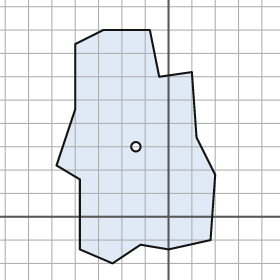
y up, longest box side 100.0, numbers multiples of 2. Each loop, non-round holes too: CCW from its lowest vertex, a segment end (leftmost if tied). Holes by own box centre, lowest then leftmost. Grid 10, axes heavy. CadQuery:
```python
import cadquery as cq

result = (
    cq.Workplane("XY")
    .moveTo(-24.0, -20.0)
    .lineTo(-12.0, -12.0)
    .lineTo(0.0, -14.0)
    .lineTo(18.0, -10.0)
    .lineTo(20.0, 18.0)
    .lineTo(12.0, 34.0)
    .lineTo(10.0, 62.0)
    .lineTo(-4.0, 60.0)
    .lineTo(-8.0, 80.0)
    .lineTo(-28.0, 80.0)
    .lineTo(-40.0, 74.0)
    .lineTo(-40.0, 46.0)
    .lineTo(-48.0, 22.0)
    .lineTo(-38.0, 16.0)
    .lineTo(-38.0, -14.0)
    .close()
    .moveTo(-14.0, 30.0)
    .circle(2.0)
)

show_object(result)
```